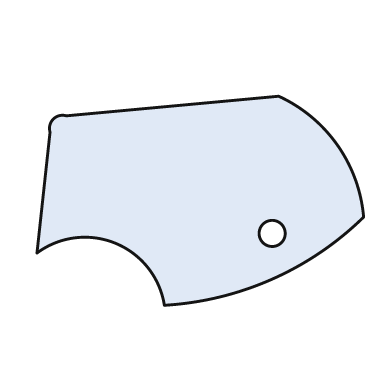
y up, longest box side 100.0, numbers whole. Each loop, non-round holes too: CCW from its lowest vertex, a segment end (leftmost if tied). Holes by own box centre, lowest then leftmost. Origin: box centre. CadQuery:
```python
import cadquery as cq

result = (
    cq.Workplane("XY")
    .moveTo(-11.0, -32.0)
    .threePointArc((22.0, -24.0), (50.0, -5.0))
    .threePointArc((42.0, 17.0), (24.0, 32.0))
    .lineTo(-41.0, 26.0)
    .threePointArc((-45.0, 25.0), (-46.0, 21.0))
    .lineTo(-50.0, -16.0)
    .threePointArc((-26.0, -13.0), (-11.0, -32.0))
    .close()
    .moveTo(22.0, -10.0)
    .circle(4.0)
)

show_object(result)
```